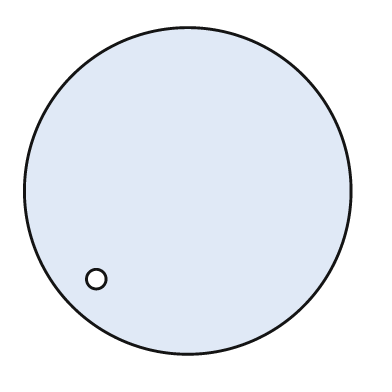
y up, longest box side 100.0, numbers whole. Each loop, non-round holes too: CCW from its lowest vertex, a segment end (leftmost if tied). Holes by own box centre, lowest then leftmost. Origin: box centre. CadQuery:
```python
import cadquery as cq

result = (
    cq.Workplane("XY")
    .moveTo(0.0, 0.0)
    .circle(50.0)
    .moveTo(-28.0, -27.0)
    .circle(3.0)
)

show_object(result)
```